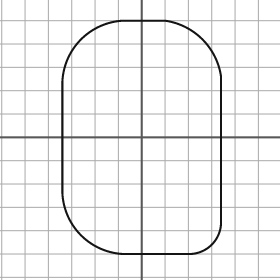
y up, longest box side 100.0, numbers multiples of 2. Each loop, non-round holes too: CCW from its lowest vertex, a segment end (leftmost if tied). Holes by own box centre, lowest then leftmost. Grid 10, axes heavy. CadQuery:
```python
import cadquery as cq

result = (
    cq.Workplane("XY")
    .moveTo(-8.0, -50.0)
    .lineTo(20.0, -50.0)
    .threePointArc((30.0, -46.0), (34.0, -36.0))
    .lineTo(34.0, 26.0)
    .threePointArc((26.0, 42.0), (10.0, 50.0))
    .lineTo(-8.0, 50.0)
    .threePointArc((-26.0, 42.0), (-34.0, 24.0))
    .lineTo(-34.0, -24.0)
    .threePointArc((-26.0, -42.0), (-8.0, -50.0))
    .close()
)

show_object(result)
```